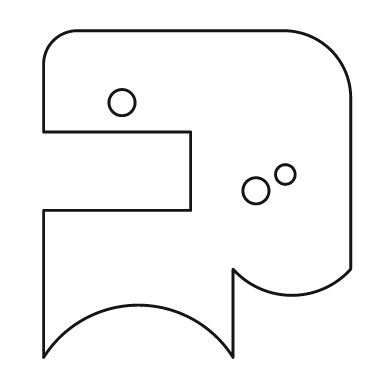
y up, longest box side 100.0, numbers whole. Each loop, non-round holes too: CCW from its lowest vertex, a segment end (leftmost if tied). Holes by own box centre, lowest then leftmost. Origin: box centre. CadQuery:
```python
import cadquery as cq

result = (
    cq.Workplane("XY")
    .moveTo(-47.0, -50.0)
    .threePointArc((-18.0, -34.0), (11.0, -50.0))
    .lineTo(11.0, -23.0)
    .threePointArc((29.0, -31.0), (47.0, -23.0))
    .lineTo(47.0, 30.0)
    .threePointArc((41.0, 44.0), (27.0, 50.0))
    .lineTo(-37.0, 50.0)
    .threePointArc((-44.0, 47.0), (-47.0, 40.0))
    .lineTo(-47.0, 19.0)
    .lineTo(-2.0, 19.0)
    .lineTo(-2.0, -5.0)
    .lineTo(-47.0, -5.0)
    .close()
    .moveTo(18.0, 1.0)
    .circle(4.0)
    .moveTo(27.0, 6.0)
    .circle(3.0)
    .moveTo(-23.0, 28.0)
    .circle(4.0)
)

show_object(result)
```